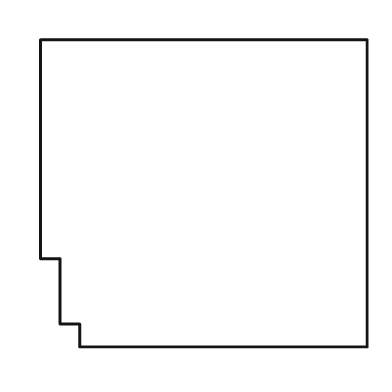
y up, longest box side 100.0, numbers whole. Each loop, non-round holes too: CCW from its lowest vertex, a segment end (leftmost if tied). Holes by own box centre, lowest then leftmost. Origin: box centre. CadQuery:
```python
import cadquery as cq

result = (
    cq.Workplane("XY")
    .moveTo(-38.0, -47.0)
    .lineTo(50.0, -47.0)
    .lineTo(50.0, 47.0)
    .lineTo(-50.0, 47.0)
    .lineTo(-50.0, -20.0)
    .lineTo(-44.0, -20.0)
    .lineTo(-44.0, -40.0)
    .lineTo(-38.0, -40.0)
    .close()
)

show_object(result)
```